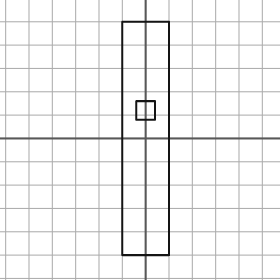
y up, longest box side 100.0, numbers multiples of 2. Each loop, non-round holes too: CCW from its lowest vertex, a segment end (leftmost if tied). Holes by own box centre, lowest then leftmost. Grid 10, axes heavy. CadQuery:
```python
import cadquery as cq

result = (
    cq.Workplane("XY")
    .moveTo(-10.0, -50.0)
    .lineTo(10.0, -50.0)
    .lineTo(10.0, 50.0)
    .lineTo(-10.0, 50.0)
    .close()
    .moveTo(-4.0, 8.0)
    .lineTo(4.0, 8.0)
    .lineTo(4.0, 16.0)
    .lineTo(-4.0, 16.0)
    .close()
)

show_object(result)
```